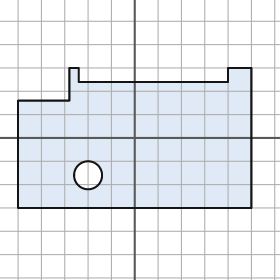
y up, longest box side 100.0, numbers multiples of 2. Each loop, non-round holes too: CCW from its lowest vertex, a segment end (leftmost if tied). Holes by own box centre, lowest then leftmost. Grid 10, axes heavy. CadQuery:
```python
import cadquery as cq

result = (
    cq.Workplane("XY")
    .moveTo(-50.0, -30.0)
    .lineTo(50.0, -30.0)
    .lineTo(50.0, 30.0)
    .lineTo(40.0, 30.0)
    .lineTo(40.0, 24.0)
    .lineTo(-24.0, 24.0)
    .lineTo(-24.0, 30.0)
    .lineTo(-28.0, 30.0)
    .lineTo(-28.0, 16.0)
    .lineTo(-50.0, 16.0)
    .close()
    .moveTo(-20.0, -16.0)
    .circle(6.0)
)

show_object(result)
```